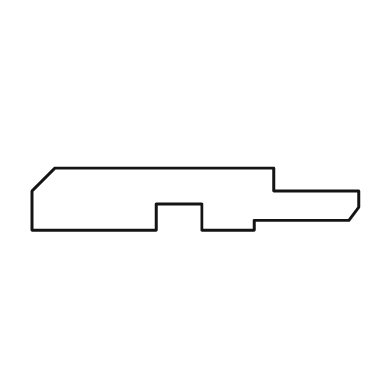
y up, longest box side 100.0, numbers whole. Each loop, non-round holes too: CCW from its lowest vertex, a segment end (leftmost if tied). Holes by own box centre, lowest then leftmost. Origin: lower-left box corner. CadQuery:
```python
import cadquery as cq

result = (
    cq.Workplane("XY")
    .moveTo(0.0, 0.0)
    .lineTo(38.0, 0.0)
    .lineTo(38.0, 8.0)
    .lineTo(52.0, 8.0)
    .lineTo(52.0, 0.0)
    .lineTo(68.0, 0.0)
    .lineTo(68.0, 3.0)
    .lineTo(97.0, 3.0)
    .lineTo(100.0, 7.0)
    .lineTo(100.0, 12.0)
    .lineTo(74.0, 12.0)
    .lineTo(74.0, 19.0)
    .lineTo(7.0, 19.0)
    .lineTo(0.0, 12.0)
    .close()
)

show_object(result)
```